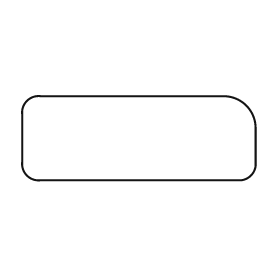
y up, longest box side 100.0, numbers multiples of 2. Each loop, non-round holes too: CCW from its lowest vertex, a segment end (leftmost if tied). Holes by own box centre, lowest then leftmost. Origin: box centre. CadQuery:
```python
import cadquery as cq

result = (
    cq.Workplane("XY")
    .moveTo(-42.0, -18.0)
    .lineTo(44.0, -18.0)
    .threePointArc((48.0, -16.0), (50.0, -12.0))
    .lineTo(50.0, 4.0)
    .threePointArc((46.0, 14.0), (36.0, 18.0))
    .lineTo(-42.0, 18.0)
    .threePointArc((-48.0, 16.0), (-50.0, 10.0))
    .lineTo(-50.0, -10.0)
    .threePointArc((-48.0, -16.0), (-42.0, -18.0))
    .close()
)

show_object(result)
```